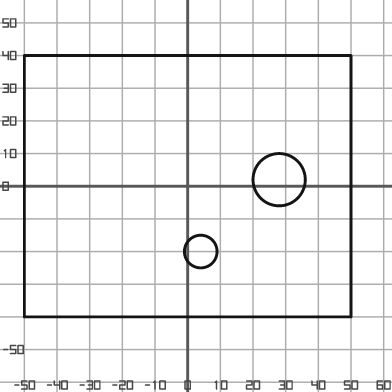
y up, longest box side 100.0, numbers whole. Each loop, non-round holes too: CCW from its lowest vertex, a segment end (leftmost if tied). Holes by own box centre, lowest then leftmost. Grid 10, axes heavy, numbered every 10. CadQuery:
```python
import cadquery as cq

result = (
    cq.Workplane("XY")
    .moveTo(-50.0, -40.0)
    .lineTo(50.0, -40.0)
    .lineTo(50.0, 40.0)
    .lineTo(-50.0, 40.0)
    .close()
    .moveTo(4.0, -20.0)
    .circle(5.0)
    .moveTo(28.0, 2.0)
    .circle(8.0)
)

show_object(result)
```